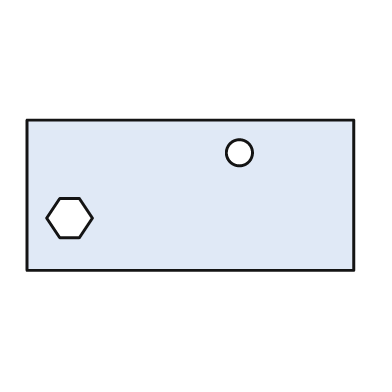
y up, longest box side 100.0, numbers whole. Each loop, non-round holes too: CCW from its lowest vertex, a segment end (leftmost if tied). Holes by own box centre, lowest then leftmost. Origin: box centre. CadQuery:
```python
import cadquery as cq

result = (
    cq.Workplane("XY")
    .moveTo(-50.0, -23.0)
    .lineTo(50.0, -23.0)
    .lineTo(50.0, 23.0)
    .lineTo(-50.0, 23.0)
    .close()
    .moveTo(-40.0, -13.0)
    .lineTo(-34.0, -13.0)
    .lineTo(-30.0, -7.0)
    .lineTo(-34.0, -1.0)
    .lineTo(-40.0, -1.0)
    .lineTo(-44.0, -7.0)
    .close()
    .moveTo(15.0, 13.0)
    .circle(4.0)
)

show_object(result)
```